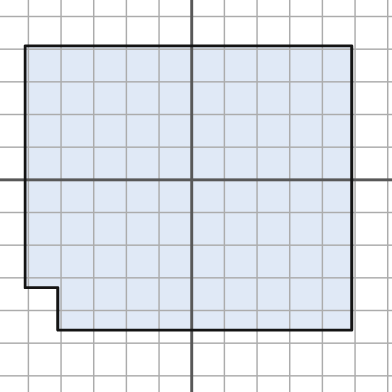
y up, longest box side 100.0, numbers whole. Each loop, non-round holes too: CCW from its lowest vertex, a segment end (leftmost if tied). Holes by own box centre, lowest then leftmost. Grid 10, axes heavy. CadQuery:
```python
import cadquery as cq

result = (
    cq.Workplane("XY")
    .moveTo(-41.0, -46.0)
    .lineTo(49.0, -46.0)
    .lineTo(49.0, 41.0)
    .lineTo(-51.0, 41.0)
    .lineTo(-51.0, -33.0)
    .lineTo(-41.0, -33.0)
    .close()
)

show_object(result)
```